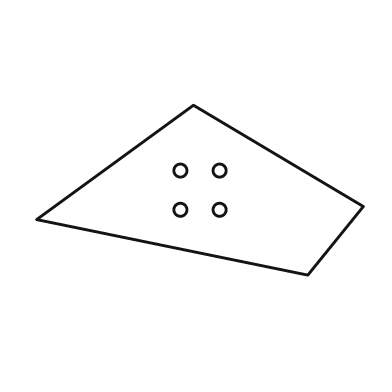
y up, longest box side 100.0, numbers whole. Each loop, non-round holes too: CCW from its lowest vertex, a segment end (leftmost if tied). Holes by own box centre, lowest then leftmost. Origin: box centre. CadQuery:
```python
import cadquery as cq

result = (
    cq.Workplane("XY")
    .moveTo(33.0, -26.0)
    .lineTo(50.0, -5.0)
    .lineTo(-2.0, 26.0)
    .lineTo(-50.0, -9.0)
    .close()
    .moveTo(-6.0, -6.0)
    .circle(2.0)
    .moveTo(6.0, -6.0)
    .circle(2.0)
    .moveTo(-6.0, 6.0)
    .circle(2.0)
    .moveTo(6.0, 6.0)
    .circle(2.0)
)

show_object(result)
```